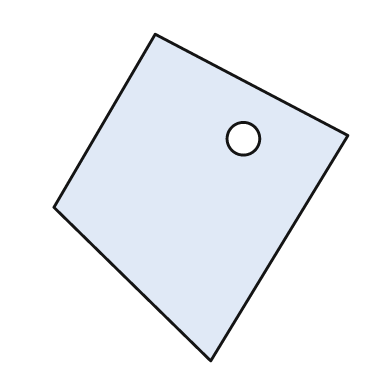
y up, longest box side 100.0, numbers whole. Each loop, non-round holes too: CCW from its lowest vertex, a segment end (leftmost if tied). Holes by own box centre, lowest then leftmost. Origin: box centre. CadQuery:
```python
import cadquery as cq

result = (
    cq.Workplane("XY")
    .moveTo(3.0, -50.0)
    .lineTo(45.0, 19.0)
    .lineTo(-14.0, 50.0)
    .lineTo(-45.0, -3.0)
    .close()
    .moveTo(13.0, 18.0)
    .circle(5.0)
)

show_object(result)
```